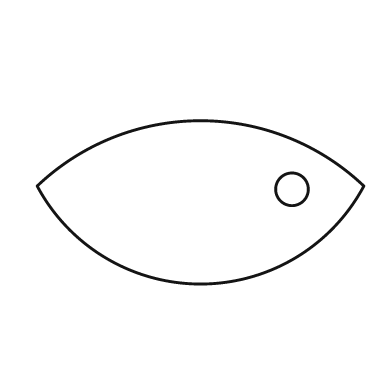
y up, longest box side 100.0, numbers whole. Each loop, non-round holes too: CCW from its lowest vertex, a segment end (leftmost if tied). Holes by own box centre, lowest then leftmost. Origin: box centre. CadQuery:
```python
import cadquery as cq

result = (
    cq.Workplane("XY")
    .moveTo(-50.0, 5.0)
    .threePointArc((0.0, -25.0), (50.0, 5.0))
    .threePointArc((0.0, 25.0), (-50.0, 5.0))
    .close()
    .moveTo(28.0, 4.0)
    .circle(5.0)
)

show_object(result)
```